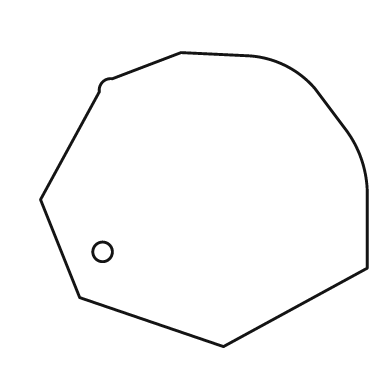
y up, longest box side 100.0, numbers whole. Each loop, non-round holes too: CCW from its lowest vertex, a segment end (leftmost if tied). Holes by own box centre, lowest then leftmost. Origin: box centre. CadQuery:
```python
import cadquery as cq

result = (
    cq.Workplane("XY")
    .moveTo(6.0, -45.0)
    .lineTo(50.0, -21.0)
    .lineTo(50.0, 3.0)
    .threePointArc((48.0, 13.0), (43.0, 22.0))
    .lineTo(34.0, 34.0)
    .threePointArc((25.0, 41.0), (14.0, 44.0))
    .lineTo(-7.0, 45.0)
    .lineTo(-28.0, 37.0)
    .threePointArc((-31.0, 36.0), (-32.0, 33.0))
    .lineTo(-50.0, 0.0)
    .lineTo(-38.0, -30.0)
    .close()
    .moveTo(-31.0, -16.0)
    .circle(3.0)
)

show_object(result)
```